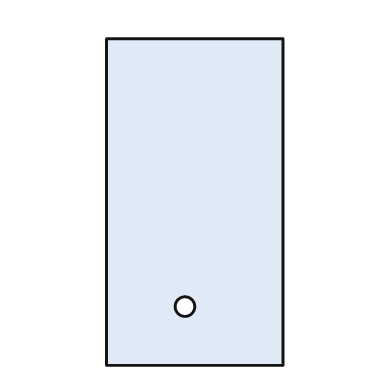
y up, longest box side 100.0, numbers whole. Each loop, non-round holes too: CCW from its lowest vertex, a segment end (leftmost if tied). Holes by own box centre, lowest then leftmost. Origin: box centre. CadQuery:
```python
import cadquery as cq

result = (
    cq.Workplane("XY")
    .moveTo(-27.0, -50.0)
    .lineTo(27.0, -50.0)
    .lineTo(27.0, 50.0)
    .lineTo(-27.0, 50.0)
    .close()
    .moveTo(-3.0, -32.0)
    .circle(3.0)
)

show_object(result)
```